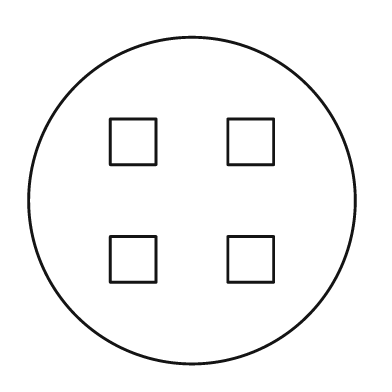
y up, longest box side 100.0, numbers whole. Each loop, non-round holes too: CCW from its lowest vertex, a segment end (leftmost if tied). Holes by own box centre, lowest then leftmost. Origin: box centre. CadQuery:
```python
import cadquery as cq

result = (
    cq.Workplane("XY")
    .moveTo(0.0, 0.0)
    .circle(50.0)
    .moveTo(-25.0, -25.0)
    .lineTo(-11.0, -25.0)
    .lineTo(-11.0, -11.0)
    .lineTo(-25.0, -11.0)
    .close()
    .moveTo(11.0, -25.0)
    .lineTo(25.0, -25.0)
    .lineTo(25.0, -11.0)
    .lineTo(11.0, -11.0)
    .close()
    .moveTo(-25.0, 11.0)
    .lineTo(-11.0, 11.0)
    .lineTo(-11.0, 25.0)
    .lineTo(-25.0, 25.0)
    .close()
    .moveTo(11.0, 11.0)
    .lineTo(25.0, 11.0)
    .lineTo(25.0, 25.0)
    .lineTo(11.0, 25.0)
    .close()
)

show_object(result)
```